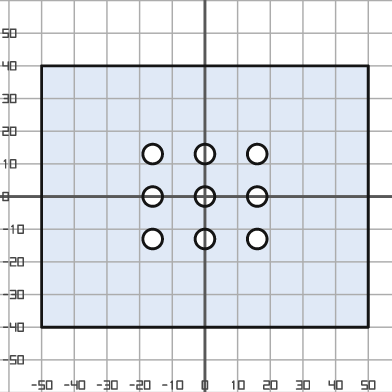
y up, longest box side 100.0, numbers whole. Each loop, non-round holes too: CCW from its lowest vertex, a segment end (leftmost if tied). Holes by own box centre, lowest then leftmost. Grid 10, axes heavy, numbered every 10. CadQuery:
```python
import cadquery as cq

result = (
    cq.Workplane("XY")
    .moveTo(-50.0, -40.0)
    .lineTo(50.0, -40.0)
    .lineTo(50.0, 40.0)
    .lineTo(-50.0, 40.0)
    .close()
    .moveTo(-16.0, -13.0)
    .circle(3.0)
    .moveTo(0.0, -13.0)
    .circle(3.0)
    .moveTo(16.0, -13.0)
    .circle(3.0)
    .moveTo(-16.0, 0.0)
    .circle(3.0)
    .moveTo(0.0, 0.0)
    .circle(3.0)
    .moveTo(16.0, 0.0)
    .circle(3.0)
    .moveTo(-16.0, 13.0)
    .circle(3.0)
    .moveTo(0.0, 13.0)
    .circle(3.0)
    .moveTo(16.0, 13.0)
    .circle(3.0)
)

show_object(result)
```